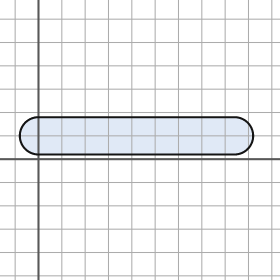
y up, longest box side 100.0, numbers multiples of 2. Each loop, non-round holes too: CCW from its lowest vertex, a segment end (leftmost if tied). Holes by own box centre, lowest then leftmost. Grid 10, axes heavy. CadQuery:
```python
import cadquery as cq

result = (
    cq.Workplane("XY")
    .moveTo(0.0, 2.0)
    .lineTo(84.0, 2.0)
    .threePointArc((92.0, 10.0), (84.0, 18.0))
    .lineTo(0.0, 18.0)
    .threePointArc((-8.0, 10.0), (0.0, 2.0))
    .close()
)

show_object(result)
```